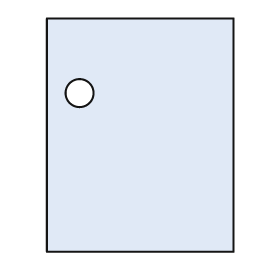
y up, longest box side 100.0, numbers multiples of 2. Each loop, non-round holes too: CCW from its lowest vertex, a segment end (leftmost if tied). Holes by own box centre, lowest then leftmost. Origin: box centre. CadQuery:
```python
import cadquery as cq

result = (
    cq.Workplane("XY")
    .moveTo(-40.0, -50.0)
    .lineTo(40.0, -50.0)
    .lineTo(40.0, 50.0)
    .lineTo(-40.0, 50.0)
    .close()
    .moveTo(-26.0, 18.0)
    .circle(6.0)
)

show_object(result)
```